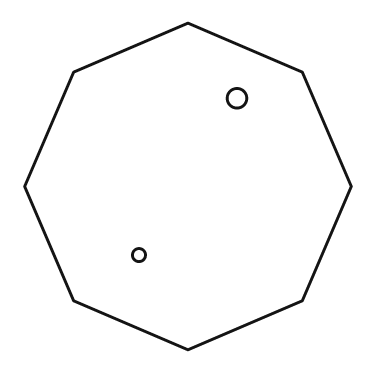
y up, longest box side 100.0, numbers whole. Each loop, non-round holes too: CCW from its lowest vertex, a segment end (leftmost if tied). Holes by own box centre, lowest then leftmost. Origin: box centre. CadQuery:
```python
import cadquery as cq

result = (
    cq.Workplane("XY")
    .moveTo(0.0, -50.0)
    .lineTo(35.0, -35.0)
    .lineTo(50.0, 0.0)
    .lineTo(35.0, 35.0)
    .lineTo(0.0, 50.0)
    .lineTo(-35.0, 35.0)
    .lineTo(-50.0, 0.0)
    .lineTo(-35.0, -35.0)
    .close()
    .moveTo(-15.0, -21.0)
    .circle(2.0)
    .moveTo(15.0, 27.0)
    .circle(3.0)
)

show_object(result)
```